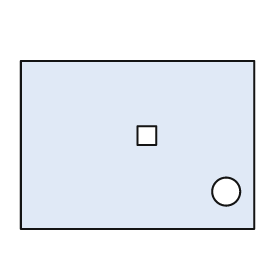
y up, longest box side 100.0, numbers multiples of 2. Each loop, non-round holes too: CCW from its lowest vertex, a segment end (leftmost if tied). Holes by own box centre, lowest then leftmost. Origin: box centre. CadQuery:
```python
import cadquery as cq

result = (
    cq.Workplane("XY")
    .moveTo(-50.0, -36.0)
    .lineTo(50.0, -36.0)
    .lineTo(50.0, 36.0)
    .lineTo(-50.0, 36.0)
    .close()
    .moveTo(38.0, -20.0)
    .circle(6.0)
    .moveTo(0.0, 0.0)
    .lineTo(8.0, 0.0)
    .lineTo(8.0, 8.0)
    .lineTo(0.0, 8.0)
    .close()
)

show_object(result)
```